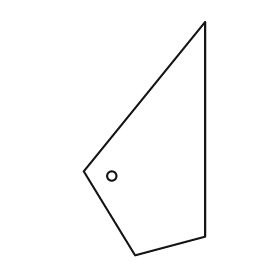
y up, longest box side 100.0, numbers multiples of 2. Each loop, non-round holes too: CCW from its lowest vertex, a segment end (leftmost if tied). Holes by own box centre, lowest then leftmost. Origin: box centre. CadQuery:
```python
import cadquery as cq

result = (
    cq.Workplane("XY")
    .moveTo(-4.0, -50.0)
    .lineTo(26.0, -42.0)
    .lineTo(26.0, 50.0)
    .lineTo(-26.0, -14.0)
    .close()
    .moveTo(-14.0, -16.0)
    .circle(2.0)
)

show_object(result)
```